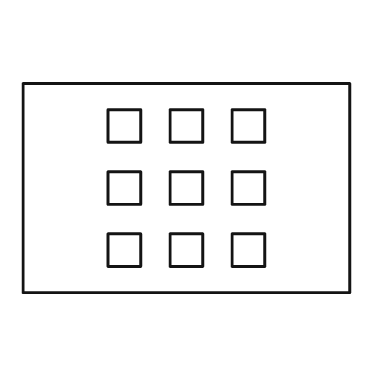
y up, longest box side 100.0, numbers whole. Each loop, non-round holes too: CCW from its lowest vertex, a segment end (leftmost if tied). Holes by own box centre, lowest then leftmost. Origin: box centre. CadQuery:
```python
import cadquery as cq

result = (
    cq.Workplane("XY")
    .moveTo(-50.0, -32.0)
    .lineTo(50.0, -32.0)
    .lineTo(50.0, 32.0)
    .lineTo(-50.0, 32.0)
    .close()
    .moveTo(-24.0, -24.0)
    .lineTo(-14.0, -24.0)
    .lineTo(-14.0, -14.0)
    .lineTo(-24.0, -14.0)
    .close()
    .moveTo(-5.0, -24.0)
    .lineTo(5.0, -24.0)
    .lineTo(5.0, -14.0)
    .lineTo(-5.0, -14.0)
    .close()
    .moveTo(14.0, -24.0)
    .lineTo(24.0, -24.0)
    .lineTo(24.0, -14.0)
    .lineTo(14.0, -14.0)
    .close()
    .moveTo(-24.0, -5.0)
    .lineTo(-14.0, -5.0)
    .lineTo(-14.0, 5.0)
    .lineTo(-24.0, 5.0)
    .close()
    .moveTo(-5.0, -5.0)
    .lineTo(5.0, -5.0)
    .lineTo(5.0, 5.0)
    .lineTo(-5.0, 5.0)
    .close()
    .moveTo(14.0, -5.0)
    .lineTo(24.0, -5.0)
    .lineTo(24.0, 5.0)
    .lineTo(14.0, 5.0)
    .close()
    .moveTo(-24.0, 14.0)
    .lineTo(-14.0, 14.0)
    .lineTo(-14.0, 24.0)
    .lineTo(-24.0, 24.0)
    .close()
    .moveTo(-5.0, 14.0)
    .lineTo(5.0, 14.0)
    .lineTo(5.0, 24.0)
    .lineTo(-5.0, 24.0)
    .close()
    .moveTo(14.0, 14.0)
    .lineTo(24.0, 14.0)
    .lineTo(24.0, 24.0)
    .lineTo(14.0, 24.0)
    .close()
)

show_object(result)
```